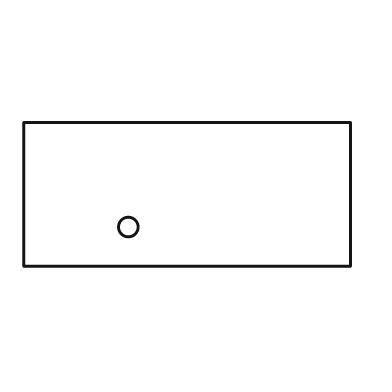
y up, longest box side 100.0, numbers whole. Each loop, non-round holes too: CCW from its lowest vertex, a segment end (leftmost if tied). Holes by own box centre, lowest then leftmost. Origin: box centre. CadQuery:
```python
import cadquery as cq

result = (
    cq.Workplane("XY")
    .moveTo(-50.0, -22.0)
    .lineTo(50.0, -22.0)
    .lineTo(50.0, 22.0)
    .lineTo(-50.0, 22.0)
    .close()
    .moveTo(-18.0, -10.0)
    .circle(3.0)
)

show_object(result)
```